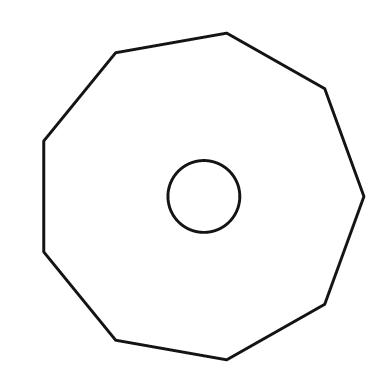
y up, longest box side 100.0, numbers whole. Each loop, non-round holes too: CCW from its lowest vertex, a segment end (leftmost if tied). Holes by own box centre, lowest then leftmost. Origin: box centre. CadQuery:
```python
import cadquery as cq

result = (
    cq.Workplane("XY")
    .moveTo(7.0, -50.0)
    .lineTo(37.0, -33.0)
    .lineTo(49.0, 0.0)
    .lineTo(37.0, 33.0)
    .lineTo(7.0, 50.0)
    .lineTo(-27.0, 44.0)
    .lineTo(-49.0, 17.0)
    .lineTo(-49.0, -17.0)
    .lineTo(-27.0, -44.0)
    .close()
    .moveTo(0.0, 0.0)
    .circle(11.0)
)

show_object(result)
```